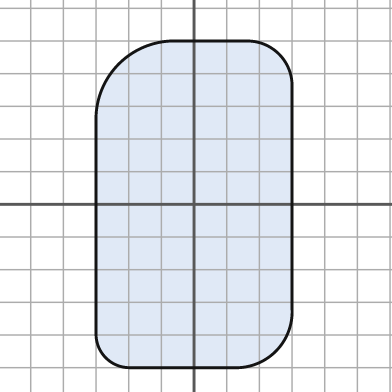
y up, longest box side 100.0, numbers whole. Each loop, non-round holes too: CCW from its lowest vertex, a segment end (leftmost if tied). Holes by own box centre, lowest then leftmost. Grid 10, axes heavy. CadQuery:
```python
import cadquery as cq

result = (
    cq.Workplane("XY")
    .moveTo(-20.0, -50.0)
    .lineTo(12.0, -50.0)
    .threePointArc((25.0, -45.0), (30.0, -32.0))
    .lineTo(30.0, 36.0)
    .threePointArc((26.0, 46.0), (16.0, 50.0))
    .lineTo(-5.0, 50.0)
    .threePointArc((-23.0, 43.0), (-30.0, 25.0))
    .lineTo(-30.0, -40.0)
    .threePointArc((-27.0, -47.0), (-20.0, -50.0))
    .close()
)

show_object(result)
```